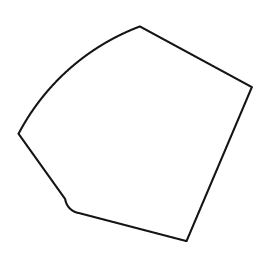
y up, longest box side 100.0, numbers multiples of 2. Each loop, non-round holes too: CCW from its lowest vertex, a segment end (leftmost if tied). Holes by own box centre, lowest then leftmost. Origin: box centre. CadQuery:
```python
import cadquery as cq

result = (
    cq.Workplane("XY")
    .moveTo(22.0, -46.0)
    .lineTo(50.0, 20.0)
    .lineTo(2.0, 46.0)
    .threePointArc((-28.0, 28.0), (-50.0, 0.0))
    .lineTo(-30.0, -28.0)
    .threePointArc((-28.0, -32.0), (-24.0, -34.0))
    .close()
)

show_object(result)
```